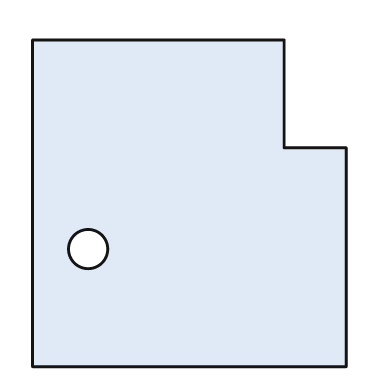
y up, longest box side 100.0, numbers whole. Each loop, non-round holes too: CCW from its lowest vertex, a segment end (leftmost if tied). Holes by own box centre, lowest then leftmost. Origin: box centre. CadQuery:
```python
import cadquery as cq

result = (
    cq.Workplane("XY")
    .moveTo(-48.0, -50.0)
    .lineTo(48.0, -50.0)
    .lineTo(48.0, 17.0)
    .lineTo(29.0, 17.0)
    .lineTo(29.0, 50.0)
    .lineTo(-48.0, 50.0)
    .close()
    .moveTo(-31.0, -14.0)
    .circle(6.0)
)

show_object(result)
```